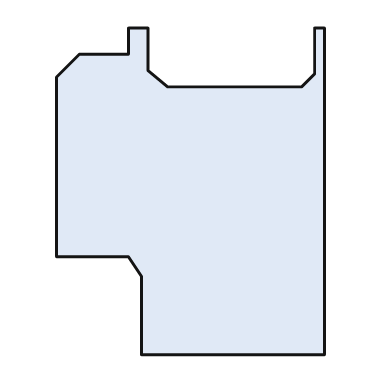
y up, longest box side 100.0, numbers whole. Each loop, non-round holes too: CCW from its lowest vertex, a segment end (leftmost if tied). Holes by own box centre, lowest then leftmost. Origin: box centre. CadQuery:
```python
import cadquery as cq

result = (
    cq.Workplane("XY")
    .moveTo(-15.0, -50.0)
    .lineTo(41.0, -50.0)
    .lineTo(41.0, 50.0)
    .lineTo(38.0, 50.0)
    .lineTo(38.0, 36.0)
    .lineTo(34.0, 32.0)
    .lineTo(-7.0, 32.0)
    .lineTo(-13.0, 37.0)
    .lineTo(-13.0, 50.0)
    .lineTo(-19.0, 50.0)
    .lineTo(-19.0, 42.0)
    .lineTo(-34.0, 42.0)
    .lineTo(-41.0, 35.0)
    .lineTo(-41.0, -20.0)
    .lineTo(-19.0, -20.0)
    .lineTo(-15.0, -26.0)
    .close()
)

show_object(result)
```